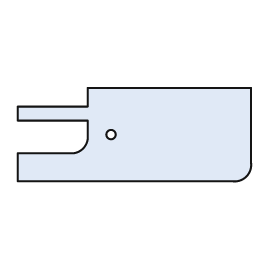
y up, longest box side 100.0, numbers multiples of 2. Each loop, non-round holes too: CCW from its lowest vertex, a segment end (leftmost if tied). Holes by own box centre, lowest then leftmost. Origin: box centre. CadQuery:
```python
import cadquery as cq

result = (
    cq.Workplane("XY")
    .moveTo(-50.0, -20.0)
    .lineTo(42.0, -20.0)
    .threePointArc((48.0, -18.0), (50.0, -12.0))
    .lineTo(50.0, 20.0)
    .lineTo(-20.0, 20.0)
    .lineTo(-20.0, 12.0)
    .lineTo(-50.0, 12.0)
    .lineTo(-50.0, 6.0)
    .lineTo(-20.0, 6.0)
    .lineTo(-20.0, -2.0)
    .threePointArc((-22.0, -6.0), (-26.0, -8.0))
    .lineTo(-50.0, -8.0)
    .close()
    .moveTo(-10.0, 0.0)
    .circle(2.0)
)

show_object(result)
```